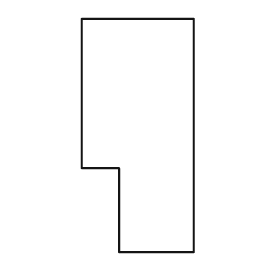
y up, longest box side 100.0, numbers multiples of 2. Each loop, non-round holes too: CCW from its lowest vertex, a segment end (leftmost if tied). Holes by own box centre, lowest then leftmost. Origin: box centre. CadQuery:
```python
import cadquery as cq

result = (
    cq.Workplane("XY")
    .moveTo(-8.0, -50.0)
    .lineTo(24.0, -50.0)
    .lineTo(24.0, 50.0)
    .lineTo(-24.0, 50.0)
    .lineTo(-24.0, -14.0)
    .lineTo(-8.0, -14.0)
    .close()
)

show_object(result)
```